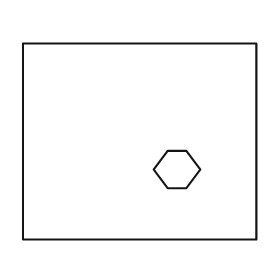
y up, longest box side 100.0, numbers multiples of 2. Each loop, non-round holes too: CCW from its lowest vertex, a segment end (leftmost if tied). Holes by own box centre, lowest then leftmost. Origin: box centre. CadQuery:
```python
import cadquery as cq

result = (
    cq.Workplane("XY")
    .moveTo(-50.0, -42.0)
    .lineTo(50.0, -42.0)
    .lineTo(50.0, 42.0)
    .lineTo(-50.0, 42.0)
    .close()
    .moveTo(12.0, -20.0)
    .lineTo(20.0, -20.0)
    .lineTo(26.0, -12.0)
    .lineTo(20.0, -4.0)
    .lineTo(12.0, -4.0)
    .lineTo(6.0, -12.0)
    .close()
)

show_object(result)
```